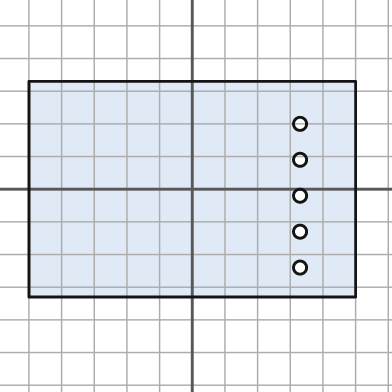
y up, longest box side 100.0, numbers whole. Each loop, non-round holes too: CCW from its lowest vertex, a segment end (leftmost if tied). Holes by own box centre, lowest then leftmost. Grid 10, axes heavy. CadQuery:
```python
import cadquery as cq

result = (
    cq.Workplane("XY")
    .moveTo(-50.0, -33.0)
    .lineTo(50.0, -33.0)
    .lineTo(50.0, 33.0)
    .lineTo(-50.0, 33.0)
    .close()
    .moveTo(33.0, -24.0)
    .circle(2.0)
    .moveTo(33.0, -13.0)
    .circle(2.0)
    .moveTo(33.0, -2.0)
    .circle(2.0)
    .moveTo(33.0, 9.0)
    .circle(2.0)
    .moveTo(33.0, 20.0)
    .circle(2.0)
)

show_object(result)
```